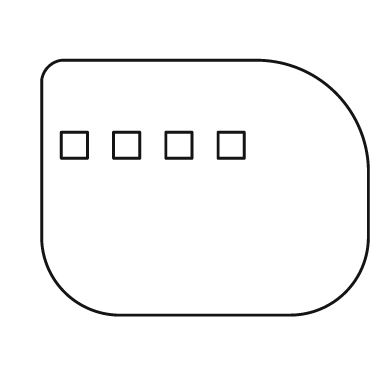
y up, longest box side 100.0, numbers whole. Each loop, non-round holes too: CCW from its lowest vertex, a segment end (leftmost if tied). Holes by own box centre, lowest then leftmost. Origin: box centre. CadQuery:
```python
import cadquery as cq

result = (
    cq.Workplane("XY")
    .moveTo(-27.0, -39.0)
    .lineTo(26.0, -39.0)
    .threePointArc((43.0, -32.0), (50.0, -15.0))
    .lineTo(50.0, 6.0)
    .threePointArc((40.0, 29.0), (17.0, 39.0))
    .lineTo(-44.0, 39.0)
    .threePointArc((-48.0, 37.0), (-50.0, 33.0))
    .lineTo(-50.0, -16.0)
    .threePointArc((-43.0, -32.0), (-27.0, -39.0))
    .close()
    .moveTo(-44.0, 9.0)
    .lineTo(-36.0, 9.0)
    .lineTo(-36.0, 17.0)
    .lineTo(-44.0, 17.0)
    .close()
    .moveTo(-28.0, 9.0)
    .lineTo(-20.0, 9.0)
    .lineTo(-20.0, 17.0)
    .lineTo(-28.0, 17.0)
    .close()
    .moveTo(-12.0, 9.0)
    .lineTo(-4.0, 9.0)
    .lineTo(-4.0, 17.0)
    .lineTo(-12.0, 17.0)
    .close()
    .moveTo(4.0, 9.0)
    .lineTo(12.0, 9.0)
    .lineTo(12.0, 17.0)
    .lineTo(4.0, 17.0)
    .close()
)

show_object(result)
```